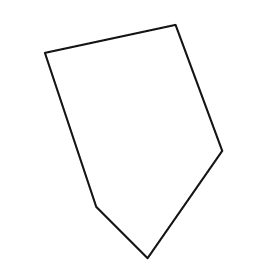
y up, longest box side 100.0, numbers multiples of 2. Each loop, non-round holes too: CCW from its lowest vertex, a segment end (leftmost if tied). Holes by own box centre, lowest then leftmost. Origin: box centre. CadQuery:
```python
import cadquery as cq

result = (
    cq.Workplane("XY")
    .moveTo(6.0, -50.0)
    .lineTo(38.0, -4.0)
    .lineTo(18.0, 50.0)
    .lineTo(-38.0, 38.0)
    .lineTo(-16.0, -28.0)
    .close()
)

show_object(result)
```